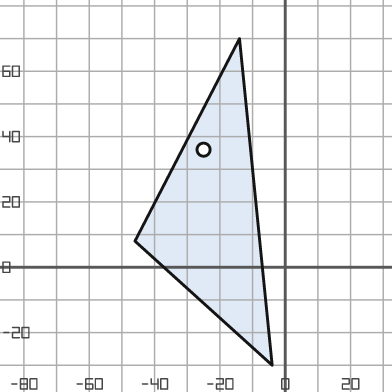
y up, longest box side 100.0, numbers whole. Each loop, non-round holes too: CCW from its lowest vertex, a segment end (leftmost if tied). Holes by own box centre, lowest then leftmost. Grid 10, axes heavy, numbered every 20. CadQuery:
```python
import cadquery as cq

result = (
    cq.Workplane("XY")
    .moveTo(-4.0, -30.0)
    .lineTo(-14.0, 70.0)
    .lineTo(-46.0, 8.0)
    .close()
    .moveTo(-25.0, 36.0)
    .circle(2.0)
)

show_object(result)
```